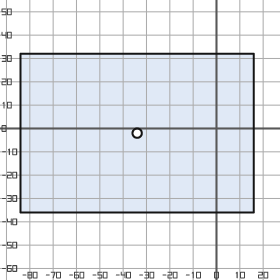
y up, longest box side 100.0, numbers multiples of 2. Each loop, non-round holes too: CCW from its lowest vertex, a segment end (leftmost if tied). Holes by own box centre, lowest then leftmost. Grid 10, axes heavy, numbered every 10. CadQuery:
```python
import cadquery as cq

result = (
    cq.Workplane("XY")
    .moveTo(-84.0, -36.0)
    .lineTo(16.0, -36.0)
    .lineTo(16.0, 32.0)
    .lineTo(-84.0, 32.0)
    .close()
    .moveTo(-34.0, -2.0)
    .circle(2.0)
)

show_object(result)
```